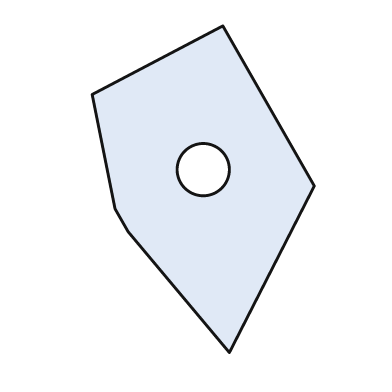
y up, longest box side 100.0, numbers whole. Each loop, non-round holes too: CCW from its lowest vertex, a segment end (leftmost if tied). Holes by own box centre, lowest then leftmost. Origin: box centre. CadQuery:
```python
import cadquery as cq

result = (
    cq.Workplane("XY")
    .moveTo(8.0, -50.0)
    .lineTo(34.0, 1.0)
    .lineTo(6.0, 50.0)
    .lineTo(-34.0, 29.0)
    .lineTo(-27.0, -6.0)
    .lineTo(-23.0, -13.0)
    .close()
    .moveTo(0.0, 6.0)
    .circle(8.0)
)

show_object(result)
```